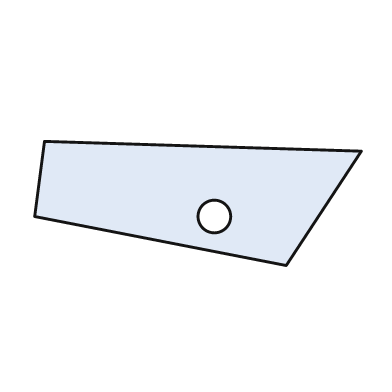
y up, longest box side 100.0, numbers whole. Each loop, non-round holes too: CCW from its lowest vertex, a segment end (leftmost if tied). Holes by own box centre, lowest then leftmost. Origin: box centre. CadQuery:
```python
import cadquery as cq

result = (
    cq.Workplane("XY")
    .moveTo(27.0, -19.0)
    .lineTo(50.0, 16.0)
    .lineTo(-47.0, 19.0)
    .lineTo(-50.0, -4.0)
    .close()
    .moveTo(5.0, -4.0)
    .circle(5.0)
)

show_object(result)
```